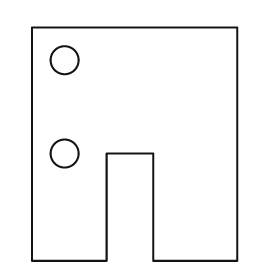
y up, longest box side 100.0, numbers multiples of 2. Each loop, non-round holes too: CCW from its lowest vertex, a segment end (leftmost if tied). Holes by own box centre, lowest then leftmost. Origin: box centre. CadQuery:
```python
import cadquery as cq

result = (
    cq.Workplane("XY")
    .moveTo(-44.0, -50.0)
    .lineTo(-12.0, -50.0)
    .lineTo(-12.0, -4.0)
    .lineTo(8.0, -4.0)
    .lineTo(8.0, -50.0)
    .lineTo(44.0, -50.0)
    .lineTo(44.0, 50.0)
    .lineTo(-44.0, 50.0)
    .close()
    .moveTo(-30.0, -4.0)
    .circle(6.0)
    .moveTo(-30.0, 36.0)
    .circle(6.0)
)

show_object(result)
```